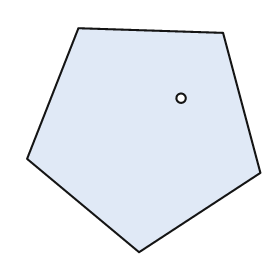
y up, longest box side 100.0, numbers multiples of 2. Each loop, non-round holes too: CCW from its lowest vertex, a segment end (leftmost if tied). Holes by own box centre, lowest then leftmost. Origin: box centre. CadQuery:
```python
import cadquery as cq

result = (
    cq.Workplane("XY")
    .moveTo(-2.0, -48.0)
    .lineTo(50.0, -14.0)
    .lineTo(34.0, 46.0)
    .lineTo(-28.0, 48.0)
    .lineTo(-50.0, -8.0)
    .close()
    .moveTo(16.0, 18.0)
    .circle(2.0)
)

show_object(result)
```